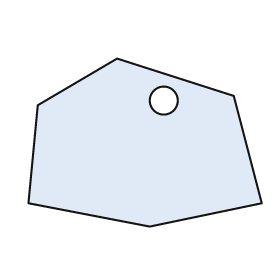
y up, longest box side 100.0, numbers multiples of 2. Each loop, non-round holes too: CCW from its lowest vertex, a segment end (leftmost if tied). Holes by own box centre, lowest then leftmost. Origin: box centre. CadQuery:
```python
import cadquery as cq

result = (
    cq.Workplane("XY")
    .moveTo(2.0, -36.0)
    .lineTo(50.0, -26.0)
    .lineTo(38.0, 20.0)
    .lineTo(-12.0, 36.0)
    .lineTo(-46.0, 16.0)
    .lineTo(-50.0, -26.0)
    .close()
    .moveTo(8.0, 18.0)
    .circle(6.0)
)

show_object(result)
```